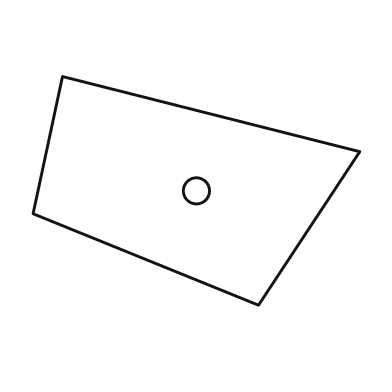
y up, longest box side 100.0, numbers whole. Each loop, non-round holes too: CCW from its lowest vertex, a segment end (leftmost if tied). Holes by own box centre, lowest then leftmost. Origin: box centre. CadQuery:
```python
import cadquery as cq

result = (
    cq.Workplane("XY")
    .moveTo(19.0, -35.0)
    .lineTo(50.0, 12.0)
    .lineTo(-41.0, 35.0)
    .lineTo(-50.0, -7.0)
    .close()
    .moveTo(0.0, 0.0)
    .circle(4.0)
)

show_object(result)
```